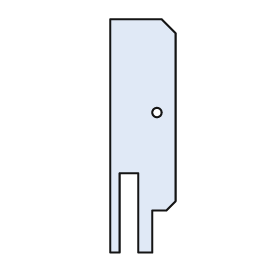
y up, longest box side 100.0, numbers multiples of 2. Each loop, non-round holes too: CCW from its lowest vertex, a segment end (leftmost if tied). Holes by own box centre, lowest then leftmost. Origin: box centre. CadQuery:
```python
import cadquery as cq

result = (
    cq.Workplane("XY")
    .moveTo(-14.0, -50.0)
    .lineTo(-10.0, -50.0)
    .lineTo(-10.0, -16.0)
    .lineTo(-2.0, -16.0)
    .lineTo(-2.0, -50.0)
    .lineTo(4.0, -50.0)
    .lineTo(4.0, -32.0)
    .lineTo(10.0, -32.0)
    .lineTo(14.0, -28.0)
    .lineTo(14.0, 44.0)
    .lineTo(8.0, 50.0)
    .lineTo(-14.0, 50.0)
    .close()
    .moveTo(6.0, 10.0)
    .circle(2.0)
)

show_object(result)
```